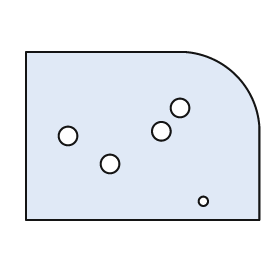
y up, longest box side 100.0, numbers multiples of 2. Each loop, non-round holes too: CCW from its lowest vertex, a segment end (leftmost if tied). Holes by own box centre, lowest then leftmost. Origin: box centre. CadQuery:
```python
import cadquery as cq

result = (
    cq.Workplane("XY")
    .moveTo(-50.0, -36.0)
    .lineTo(50.0, -36.0)
    .lineTo(50.0, 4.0)
    .threePointArc((40.0, 26.0), (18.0, 36.0))
    .lineTo(-50.0, 36.0)
    .close()
    .moveTo(26.0, -28.0)
    .circle(2.0)
    .moveTo(-14.0, -12.0)
    .circle(4.0)
    .moveTo(-32.0, 0.0)
    .circle(4.0)
    .moveTo(8.0, 2.0)
    .circle(4.0)
    .moveTo(16.0, 12.0)
    .circle(4.0)
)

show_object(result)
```